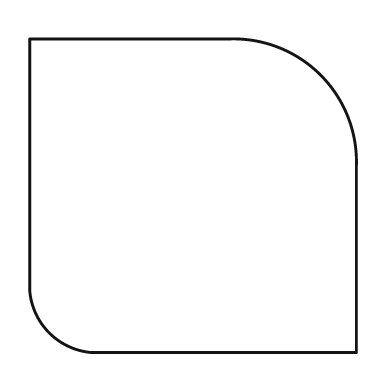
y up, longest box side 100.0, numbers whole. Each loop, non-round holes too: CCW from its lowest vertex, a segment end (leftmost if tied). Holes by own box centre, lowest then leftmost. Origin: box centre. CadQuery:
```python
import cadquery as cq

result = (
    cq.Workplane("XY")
    .moveTo(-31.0, -48.0)
    .lineTo(50.0, -48.0)
    .lineTo(50.0, 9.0)
    .threePointArc((39.0, 37.0), (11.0, 48.0))
    .lineTo(-50.0, 48.0)
    .lineTo(-50.0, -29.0)
    .threePointArc((-44.0, -42.0), (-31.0, -48.0))
    .close()
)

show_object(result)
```